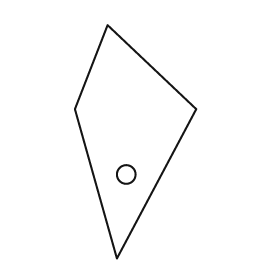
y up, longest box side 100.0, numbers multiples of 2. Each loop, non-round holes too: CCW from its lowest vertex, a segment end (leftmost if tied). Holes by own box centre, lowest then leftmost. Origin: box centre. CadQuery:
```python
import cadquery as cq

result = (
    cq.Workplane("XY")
    .moveTo(-8.0, -50.0)
    .lineTo(26.0, 14.0)
    .lineTo(-12.0, 50.0)
    .lineTo(-26.0, 14.0)
    .close()
    .moveTo(-4.0, -14.0)
    .circle(4.0)
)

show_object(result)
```